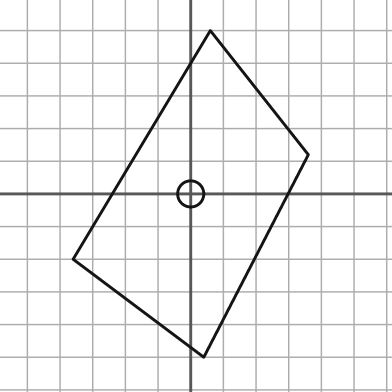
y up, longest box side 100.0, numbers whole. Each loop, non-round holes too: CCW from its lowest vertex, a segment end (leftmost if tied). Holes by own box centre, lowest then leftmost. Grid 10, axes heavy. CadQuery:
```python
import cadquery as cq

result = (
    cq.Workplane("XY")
    .moveTo(4.0, -50.0)
    .lineTo(36.0, 12.0)
    .lineTo(6.0, 50.0)
    .lineTo(-36.0, -20.0)
    .close()
    .moveTo(0.0, 0.0)
    .circle(4.0)
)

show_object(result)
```